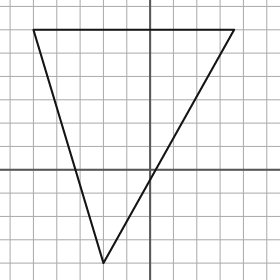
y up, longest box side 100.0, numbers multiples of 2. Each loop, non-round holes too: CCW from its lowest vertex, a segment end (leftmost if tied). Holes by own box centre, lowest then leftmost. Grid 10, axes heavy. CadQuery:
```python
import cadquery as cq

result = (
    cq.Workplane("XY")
    .moveTo(-20.0, -40.0)
    .lineTo(36.0, 60.0)
    .lineTo(-50.0, 60.0)
    .close()
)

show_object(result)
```